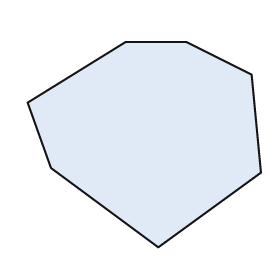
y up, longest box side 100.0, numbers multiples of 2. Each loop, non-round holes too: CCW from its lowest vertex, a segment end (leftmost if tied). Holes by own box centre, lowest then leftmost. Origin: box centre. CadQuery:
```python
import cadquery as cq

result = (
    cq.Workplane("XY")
    .moveTo(6.0, -44.0)
    .lineTo(50.0, -12.0)
    .lineTo(46.0, 30.0)
    .lineTo(18.0, 44.0)
    .lineTo(-8.0, 44.0)
    .lineTo(-50.0, 18.0)
    .lineTo(-40.0, -10.0)
    .close()
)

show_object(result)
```